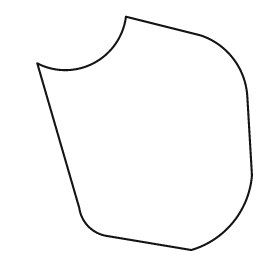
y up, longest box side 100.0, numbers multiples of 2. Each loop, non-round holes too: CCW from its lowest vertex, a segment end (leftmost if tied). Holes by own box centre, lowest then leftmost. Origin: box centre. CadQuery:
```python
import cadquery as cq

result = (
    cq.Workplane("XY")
    .moveTo(20.0, -50.0)
    .threePointArc((38.0, -38.0), (46.0, -18.0))
    .lineTo(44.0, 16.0)
    .threePointArc((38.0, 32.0), (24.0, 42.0))
    .lineTo(-8.0, 50.0)
    .threePointArc((-22.0, 30.0), (-46.0, 30.0))
    .lineTo(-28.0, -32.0)
    .threePointArc((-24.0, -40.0), (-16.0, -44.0))
    .close()
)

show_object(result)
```